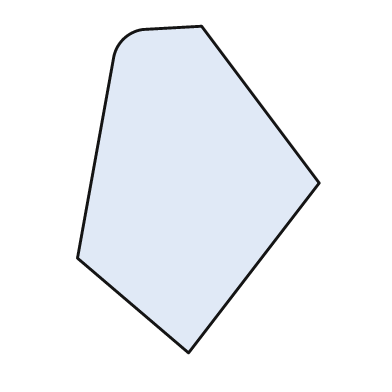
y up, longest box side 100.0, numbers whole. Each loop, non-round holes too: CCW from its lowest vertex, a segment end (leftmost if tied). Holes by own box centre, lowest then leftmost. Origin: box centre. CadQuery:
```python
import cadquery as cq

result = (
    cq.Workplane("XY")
    .moveTo(-3.0, -50.0)
    .lineTo(37.0, 2.0)
    .lineTo(1.0, 50.0)
    .lineTo(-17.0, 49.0)
    .threePointArc((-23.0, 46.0), (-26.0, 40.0))
    .lineTo(-37.0, -21.0)
    .close()
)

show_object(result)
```